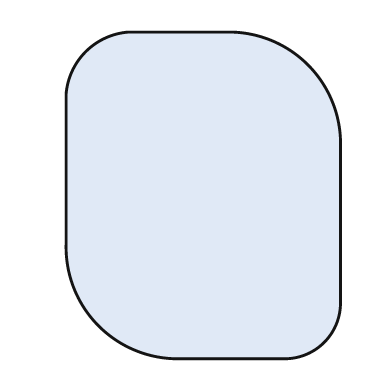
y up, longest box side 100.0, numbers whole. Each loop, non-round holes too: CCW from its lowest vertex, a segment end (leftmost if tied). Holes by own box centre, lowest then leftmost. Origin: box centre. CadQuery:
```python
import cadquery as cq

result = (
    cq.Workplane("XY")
    .moveTo(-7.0, -50.0)
    .lineTo(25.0, -50.0)
    .threePointArc((37.0, -45.0), (42.0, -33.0))
    .lineTo(42.0, 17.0)
    .threePointArc((32.0, 40.0), (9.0, 50.0))
    .lineTo(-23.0, 50.0)
    .threePointArc((-36.0, 44.0), (-42.0, 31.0))
    .lineTo(-42.0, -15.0)
    .threePointArc((-32.0, -40.0), (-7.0, -50.0))
    .close()
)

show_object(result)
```